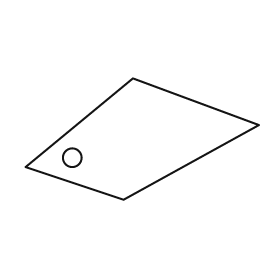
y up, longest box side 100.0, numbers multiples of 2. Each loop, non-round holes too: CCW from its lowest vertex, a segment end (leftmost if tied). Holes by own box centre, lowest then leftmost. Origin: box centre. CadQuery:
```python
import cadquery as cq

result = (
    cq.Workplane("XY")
    .moveTo(-8.0, -26.0)
    .lineTo(50.0, 6.0)
    .lineTo(-4.0, 26.0)
    .lineTo(-50.0, -12.0)
    .close()
    .moveTo(-30.0, -8.0)
    .circle(4.0)
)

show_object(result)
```